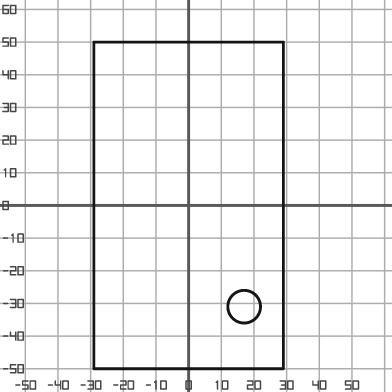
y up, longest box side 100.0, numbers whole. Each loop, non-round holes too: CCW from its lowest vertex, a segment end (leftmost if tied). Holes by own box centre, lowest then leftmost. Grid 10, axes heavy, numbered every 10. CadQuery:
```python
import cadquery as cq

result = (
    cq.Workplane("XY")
    .moveTo(-29.0, -50.0)
    .lineTo(29.0, -50.0)
    .lineTo(29.0, 50.0)
    .lineTo(-29.0, 50.0)
    .close()
    .moveTo(17.0, -31.0)
    .circle(5.0)
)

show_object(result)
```